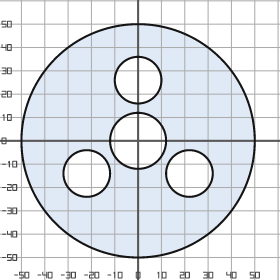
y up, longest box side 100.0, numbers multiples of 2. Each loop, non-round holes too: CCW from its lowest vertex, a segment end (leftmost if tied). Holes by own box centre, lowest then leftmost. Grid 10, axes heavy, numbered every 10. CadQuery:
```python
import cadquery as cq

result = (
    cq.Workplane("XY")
    .moveTo(0.0, 0.0)
    .circle(50.0)
    .moveTo(-22.0, -14.0)
    .circle(10.0)
    .moveTo(22.0, -14.0)
    .circle(10.0)
    .moveTo(0.0, 0.0)
    .circle(12.0)
    .moveTo(0.0, 26.0)
    .circle(10.0)
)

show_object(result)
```